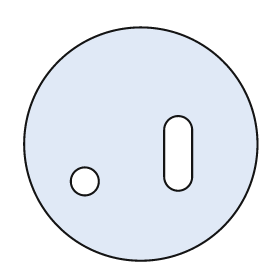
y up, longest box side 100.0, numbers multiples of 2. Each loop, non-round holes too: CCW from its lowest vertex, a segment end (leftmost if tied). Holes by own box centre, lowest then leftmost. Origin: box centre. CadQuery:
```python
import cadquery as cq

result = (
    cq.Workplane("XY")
    .moveTo(0.0, 0.0)
    .circle(50.0)
    .moveTo(-24.0, -16.0)
    .circle(6.0)
    .moveTo(10.0, -14.0)
    .threePointArc((16.0, -20.0), (22.0, -14.0))
    .lineTo(22.0, 6.0)
    .threePointArc((16.0, 12.0), (10.0, 6.0))
    .close()
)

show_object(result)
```